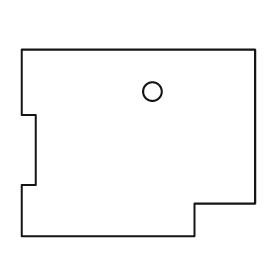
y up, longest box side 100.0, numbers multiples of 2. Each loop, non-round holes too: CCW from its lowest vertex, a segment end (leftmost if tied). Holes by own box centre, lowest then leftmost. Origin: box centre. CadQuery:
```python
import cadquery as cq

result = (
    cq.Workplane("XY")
    .moveTo(-50.0, -40.0)
    .lineTo(24.0, -40.0)
    .lineTo(24.0, -26.0)
    .lineTo(50.0, -26.0)
    .lineTo(50.0, 40.0)
    .lineTo(-50.0, 40.0)
    .lineTo(-50.0, 12.0)
    .lineTo(-44.0, 12.0)
    .lineTo(-44.0, -18.0)
    .lineTo(-50.0, -18.0)
    .close()
    .moveTo(6.0, 22.0)
    .circle(4.0)
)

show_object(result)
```